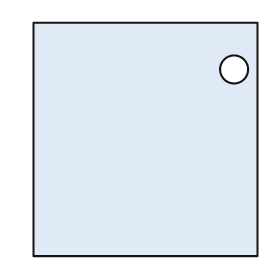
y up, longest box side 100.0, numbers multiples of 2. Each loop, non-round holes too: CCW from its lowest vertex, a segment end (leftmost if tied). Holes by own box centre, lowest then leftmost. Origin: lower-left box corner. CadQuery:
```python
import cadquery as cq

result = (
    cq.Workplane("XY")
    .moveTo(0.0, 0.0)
    .lineTo(96.0, 0.0)
    .lineTo(96.0, 100.0)
    .lineTo(0.0, 100.0)
    .close()
    .moveTo(86.0, 80.0)
    .circle(6.0)
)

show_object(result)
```